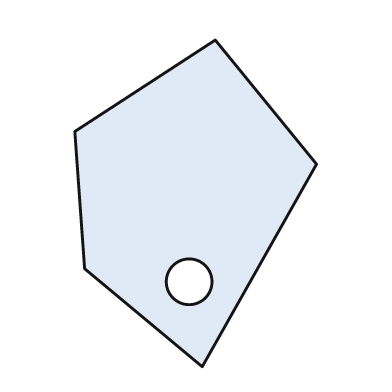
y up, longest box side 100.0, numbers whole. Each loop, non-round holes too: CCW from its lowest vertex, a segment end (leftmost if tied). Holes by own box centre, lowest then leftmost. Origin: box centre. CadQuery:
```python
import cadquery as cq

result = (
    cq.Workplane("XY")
    .moveTo(2.0, -50.0)
    .lineTo(37.0, 12.0)
    .lineTo(6.0, 50.0)
    .lineTo(-37.0, 22.0)
    .lineTo(-34.0, -20.0)
    .close()
    .moveTo(-2.0, -24.0)
    .circle(7.0)
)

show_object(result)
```